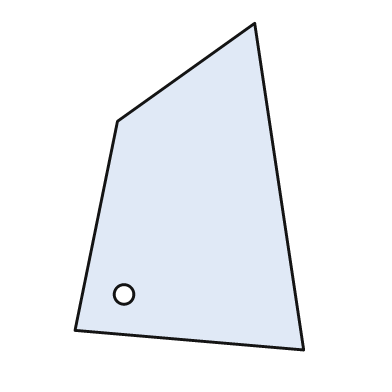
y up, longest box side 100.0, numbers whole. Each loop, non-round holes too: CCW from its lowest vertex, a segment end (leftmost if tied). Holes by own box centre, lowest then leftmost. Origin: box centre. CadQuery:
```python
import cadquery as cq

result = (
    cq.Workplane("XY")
    .moveTo(35.0, -50.0)
    .lineTo(20.0, 50.0)
    .lineTo(-22.0, 20.0)
    .lineTo(-35.0, -44.0)
    .close()
    .moveTo(-20.0, -33.0)
    .circle(3.0)
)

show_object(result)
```